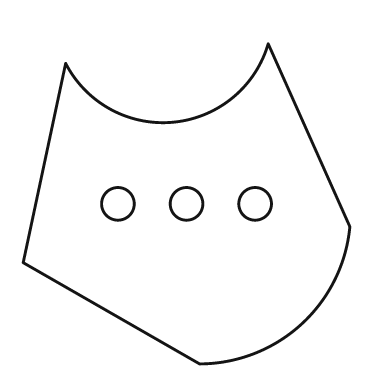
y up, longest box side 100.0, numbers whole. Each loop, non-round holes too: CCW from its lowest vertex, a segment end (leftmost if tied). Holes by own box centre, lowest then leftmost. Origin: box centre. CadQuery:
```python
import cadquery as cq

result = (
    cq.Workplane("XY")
    .moveTo(4.0, -49.0)
    .threePointArc((35.0, -37.0), (50.0, -7.0))
    .lineTo(25.0, 49.0)
    .threePointArc((-4.0, 25.0), (-37.0, 43.0))
    .lineTo(-50.0, -18.0)
    .close()
    .moveTo(-21.0, 0.0)
    .circle(5.0)
    .moveTo(0.0, 0.0)
    .circle(5.0)
    .moveTo(21.0, 0.0)
    .circle(5.0)
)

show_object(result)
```